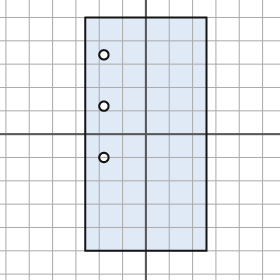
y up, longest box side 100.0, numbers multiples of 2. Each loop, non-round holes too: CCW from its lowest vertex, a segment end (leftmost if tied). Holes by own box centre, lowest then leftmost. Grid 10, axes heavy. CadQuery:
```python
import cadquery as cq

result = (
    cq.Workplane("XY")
    .moveTo(-26.0, -50.0)
    .lineTo(26.0, -50.0)
    .lineTo(26.0, 50.0)
    .lineTo(-26.0, 50.0)
    .close()
    .moveTo(-18.0, -10.0)
    .circle(2.0)
    .moveTo(-18.0, 12.0)
    .circle(2.0)
    .moveTo(-18.0, 34.0)
    .circle(2.0)
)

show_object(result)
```